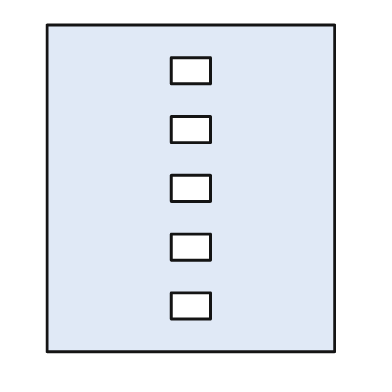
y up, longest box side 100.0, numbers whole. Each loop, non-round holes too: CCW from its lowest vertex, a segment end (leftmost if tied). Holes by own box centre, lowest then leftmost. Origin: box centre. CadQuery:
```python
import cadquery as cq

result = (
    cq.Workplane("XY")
    .moveTo(-44.0, -50.0)
    .lineTo(44.0, -50.0)
    .lineTo(44.0, 50.0)
    .lineTo(-44.0, 50.0)
    .close()
    .moveTo(-6.0, -40.0)
    .lineTo(6.0, -40.0)
    .lineTo(6.0, -32.0)
    .lineTo(-6.0, -32.0)
    .close()
    .moveTo(-6.0, -22.0)
    .lineTo(6.0, -22.0)
    .lineTo(6.0, -14.0)
    .lineTo(-6.0, -14.0)
    .close()
    .moveTo(-6.0, -4.0)
    .lineTo(6.0, -4.0)
    .lineTo(6.0, 4.0)
    .lineTo(-6.0, 4.0)
    .close()
    .moveTo(-6.0, 14.0)
    .lineTo(6.0, 14.0)
    .lineTo(6.0, 22.0)
    .lineTo(-6.0, 22.0)
    .close()
    .moveTo(-6.0, 32.0)
    .lineTo(6.0, 32.0)
    .lineTo(6.0, 40.0)
    .lineTo(-6.0, 40.0)
    .close()
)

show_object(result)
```